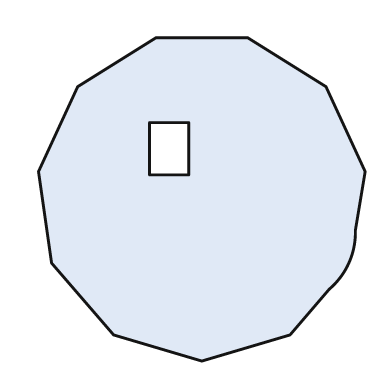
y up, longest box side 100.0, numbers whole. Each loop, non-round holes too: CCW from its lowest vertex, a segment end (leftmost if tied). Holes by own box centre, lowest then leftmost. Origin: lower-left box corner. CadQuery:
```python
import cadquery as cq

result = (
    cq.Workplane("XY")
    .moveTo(50.0, 0.0)
    .lineTo(77.0, 8.0)
    .lineTo(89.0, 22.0)
    .threePointArc((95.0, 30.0), (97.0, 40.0))
    .lineTo(100.0, 58.0)
    .lineTo(88.0, 84.0)
    .lineTo(64.0, 99.0)
    .lineTo(36.0, 99.0)
    .lineTo(12.0, 84.0)
    .lineTo(0.0, 58.0)
    .lineTo(4.0, 30.0)
    .lineTo(23.0, 8.0)
    .close()
    .moveTo(34.0, 57.0)
    .lineTo(46.0, 57.0)
    .lineTo(46.0, 73.0)
    .lineTo(34.0, 73.0)
    .close()
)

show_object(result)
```